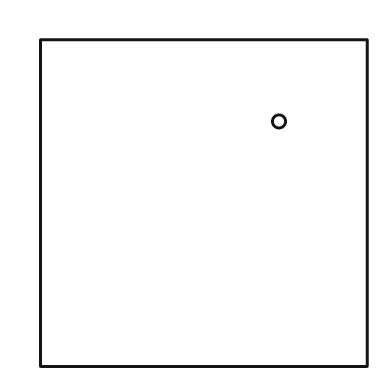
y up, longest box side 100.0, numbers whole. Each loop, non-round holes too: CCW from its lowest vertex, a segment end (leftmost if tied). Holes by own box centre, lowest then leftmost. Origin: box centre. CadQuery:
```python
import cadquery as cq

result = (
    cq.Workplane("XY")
    .moveTo(-50.0, -50.0)
    .lineTo(50.0, -50.0)
    .lineTo(50.0, 50.0)
    .lineTo(-50.0, 50.0)
    .close()
    .moveTo(23.0, 25.0)
    .circle(2.0)
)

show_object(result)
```